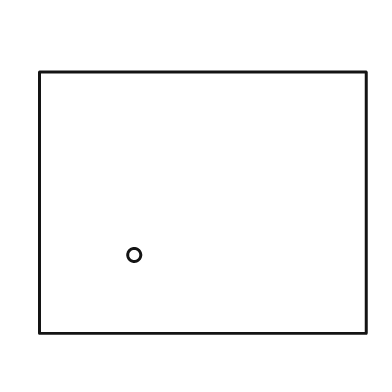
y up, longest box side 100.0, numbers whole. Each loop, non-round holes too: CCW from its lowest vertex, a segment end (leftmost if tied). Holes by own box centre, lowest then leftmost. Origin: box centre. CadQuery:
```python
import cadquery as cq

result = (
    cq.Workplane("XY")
    .moveTo(-50.0, -40.0)
    .lineTo(50.0, -40.0)
    .lineTo(50.0, 40.0)
    .lineTo(-50.0, 40.0)
    .close()
    .moveTo(-21.0, -16.0)
    .circle(2.0)
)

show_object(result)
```